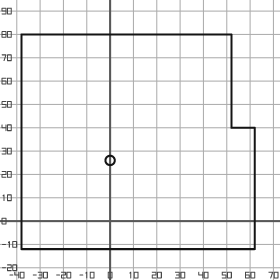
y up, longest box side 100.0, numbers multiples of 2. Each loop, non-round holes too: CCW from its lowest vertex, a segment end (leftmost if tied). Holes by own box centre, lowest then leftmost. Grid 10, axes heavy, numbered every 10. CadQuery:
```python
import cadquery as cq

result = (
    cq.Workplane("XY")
    .moveTo(-38.0, -12.0)
    .lineTo(62.0, -12.0)
    .lineTo(62.0, 40.0)
    .lineTo(52.0, 40.0)
    .lineTo(52.0, 80.0)
    .lineTo(-38.0, 80.0)
    .close()
    .moveTo(0.0, 26.0)
    .circle(2.0)
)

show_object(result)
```